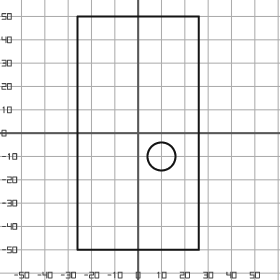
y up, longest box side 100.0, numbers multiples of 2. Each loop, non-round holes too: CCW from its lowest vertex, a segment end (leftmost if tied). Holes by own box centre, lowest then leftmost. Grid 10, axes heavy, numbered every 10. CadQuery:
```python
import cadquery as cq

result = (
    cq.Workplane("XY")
    .moveTo(-26.0, -50.0)
    .lineTo(26.0, -50.0)
    .lineTo(26.0, 50.0)
    .lineTo(-26.0, 50.0)
    .close()
    .moveTo(10.0, -10.0)
    .circle(6.0)
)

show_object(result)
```